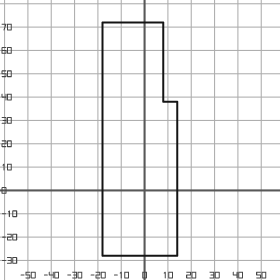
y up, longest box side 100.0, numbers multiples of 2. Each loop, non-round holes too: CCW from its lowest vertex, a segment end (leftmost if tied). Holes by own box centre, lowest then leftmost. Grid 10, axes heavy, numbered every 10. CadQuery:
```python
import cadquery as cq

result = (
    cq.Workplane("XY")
    .moveTo(-18.0, -28.0)
    .lineTo(14.0, -28.0)
    .lineTo(14.0, 38.0)
    .lineTo(8.0, 38.0)
    .lineTo(8.0, 72.0)
    .lineTo(-18.0, 72.0)
    .close()
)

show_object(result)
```